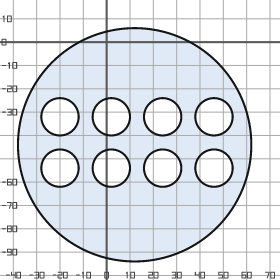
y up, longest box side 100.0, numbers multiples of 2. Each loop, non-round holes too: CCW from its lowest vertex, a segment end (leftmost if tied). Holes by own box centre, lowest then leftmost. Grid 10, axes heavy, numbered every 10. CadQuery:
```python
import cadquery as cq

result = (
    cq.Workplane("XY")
    .moveTo(12.0, -44.0)
    .circle(50.0)
    .moveTo(-20.0, -54.0)
    .circle(8.0)
    .moveTo(2.0, -54.0)
    .circle(8.0)
    .moveTo(24.0, -54.0)
    .circle(8.0)
    .moveTo(46.0, -54.0)
    .circle(8.0)
    .moveTo(-20.0, -32.0)
    .circle(8.0)
    .moveTo(2.0, -32.0)
    .circle(8.0)
    .moveTo(24.0, -32.0)
    .circle(8.0)
    .moveTo(46.0, -32.0)
    .circle(8.0)
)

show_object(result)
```